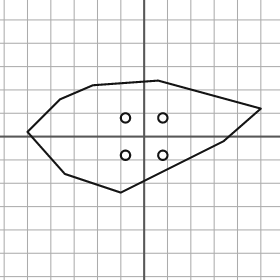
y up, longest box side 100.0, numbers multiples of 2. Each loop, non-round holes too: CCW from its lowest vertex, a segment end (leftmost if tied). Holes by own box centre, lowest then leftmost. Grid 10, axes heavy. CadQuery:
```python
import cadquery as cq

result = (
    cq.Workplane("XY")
    .moveTo(-10.0, -24.0)
    .lineTo(34.0, -2.0)
    .lineTo(50.0, 12.0)
    .lineTo(6.0, 24.0)
    .lineTo(-22.0, 22.0)
    .lineTo(-36.0, 16.0)
    .lineTo(-50.0, 2.0)
    .lineTo(-34.0, -16.0)
    .close()
    .moveTo(-8.0, -8.0)
    .circle(2.0)
    .moveTo(8.0, -8.0)
    .circle(2.0)
    .moveTo(-8.0, 8.0)
    .circle(2.0)
    .moveTo(8.0, 8.0)
    .circle(2.0)
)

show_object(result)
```